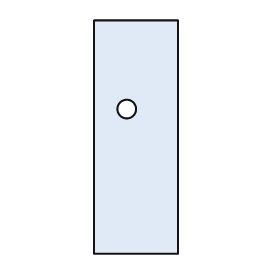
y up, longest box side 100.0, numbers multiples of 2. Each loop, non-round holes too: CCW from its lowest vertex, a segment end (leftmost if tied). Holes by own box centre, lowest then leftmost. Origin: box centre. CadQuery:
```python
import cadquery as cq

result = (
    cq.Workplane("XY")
    .moveTo(-18.0, -50.0)
    .lineTo(18.0, -50.0)
    .lineTo(18.0, 50.0)
    .lineTo(-18.0, 50.0)
    .close()
    .moveTo(-4.0, 12.0)
    .circle(4.0)
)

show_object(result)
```